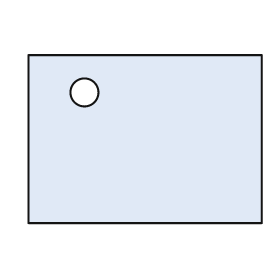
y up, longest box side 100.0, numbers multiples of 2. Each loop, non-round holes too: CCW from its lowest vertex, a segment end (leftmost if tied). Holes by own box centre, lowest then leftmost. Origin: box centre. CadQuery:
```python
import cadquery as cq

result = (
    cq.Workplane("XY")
    .moveTo(-50.0, -36.0)
    .lineTo(50.0, -36.0)
    .lineTo(50.0, 36.0)
    .lineTo(-50.0, 36.0)
    .close()
    .moveTo(-26.0, 20.0)
    .circle(6.0)
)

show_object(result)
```